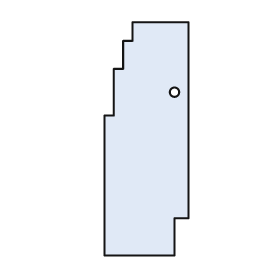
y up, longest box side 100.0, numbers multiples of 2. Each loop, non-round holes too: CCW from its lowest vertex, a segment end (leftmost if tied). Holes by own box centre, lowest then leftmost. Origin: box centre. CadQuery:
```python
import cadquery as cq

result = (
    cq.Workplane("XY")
    .moveTo(-18.0, -50.0)
    .lineTo(12.0, -50.0)
    .lineTo(12.0, -34.0)
    .lineTo(18.0, -34.0)
    .lineTo(18.0, 50.0)
    .lineTo(-6.0, 50.0)
    .lineTo(-6.0, 42.0)
    .lineTo(-10.0, 42.0)
    .lineTo(-10.0, 30.0)
    .lineTo(-14.0, 30.0)
    .lineTo(-14.0, 10.0)
    .lineTo(-18.0, 10.0)
    .close()
    .moveTo(12.0, 20.0)
    .circle(2.0)
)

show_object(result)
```